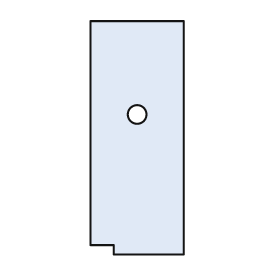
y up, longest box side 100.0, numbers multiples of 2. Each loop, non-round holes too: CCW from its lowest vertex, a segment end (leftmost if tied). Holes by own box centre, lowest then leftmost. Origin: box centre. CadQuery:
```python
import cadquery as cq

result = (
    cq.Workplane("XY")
    .moveTo(-10.0, -50.0)
    .lineTo(20.0, -50.0)
    .lineTo(20.0, 50.0)
    .lineTo(-20.0, 50.0)
    .lineTo(-20.0, -46.0)
    .lineTo(-10.0, -46.0)
    .close()
    .moveTo(0.0, 10.0)
    .circle(4.0)
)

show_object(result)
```